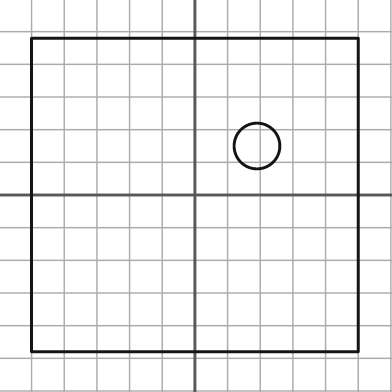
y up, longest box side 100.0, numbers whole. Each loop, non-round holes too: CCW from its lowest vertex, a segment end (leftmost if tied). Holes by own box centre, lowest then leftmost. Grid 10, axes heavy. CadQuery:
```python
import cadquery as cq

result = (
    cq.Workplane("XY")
    .moveTo(-50.0, -48.0)
    .lineTo(50.0, -48.0)
    .lineTo(50.0, 48.0)
    .lineTo(-50.0, 48.0)
    .close()
    .moveTo(19.0, 15.0)
    .circle(7.0)
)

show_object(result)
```